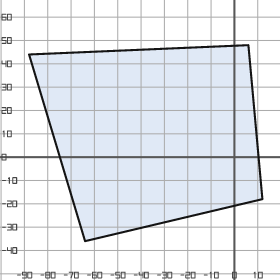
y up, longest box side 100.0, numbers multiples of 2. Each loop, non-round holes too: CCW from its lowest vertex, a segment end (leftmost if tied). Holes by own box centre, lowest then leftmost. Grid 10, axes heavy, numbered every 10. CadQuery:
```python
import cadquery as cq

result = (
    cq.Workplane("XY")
    .moveTo(-64.0, -36.0)
    .lineTo(12.0, -18.0)
    .lineTo(6.0, 48.0)
    .lineTo(-88.0, 44.0)
    .close()
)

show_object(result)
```